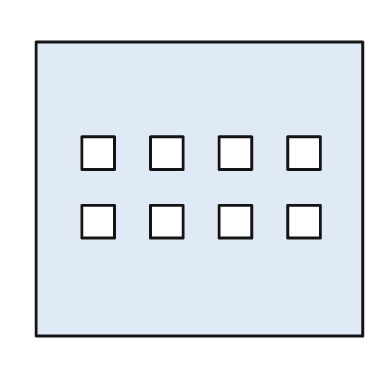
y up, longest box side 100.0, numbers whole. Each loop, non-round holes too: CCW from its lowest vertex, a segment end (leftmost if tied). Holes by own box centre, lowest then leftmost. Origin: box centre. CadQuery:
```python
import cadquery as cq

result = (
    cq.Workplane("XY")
    .moveTo(-50.0, -45.0)
    .lineTo(50.0, -45.0)
    .lineTo(50.0, 45.0)
    .lineTo(-50.0, 45.0)
    .close()
    .moveTo(-36.0, -15.0)
    .lineTo(-26.0, -15.0)
    .lineTo(-26.0, -5.0)
    .lineTo(-36.0, -5.0)
    .close()
    .moveTo(-15.0, -15.0)
    .lineTo(-5.0, -15.0)
    .lineTo(-5.0, -5.0)
    .lineTo(-15.0, -5.0)
    .close()
    .moveTo(6.0, -15.0)
    .lineTo(16.0, -15.0)
    .lineTo(16.0, -5.0)
    .lineTo(6.0, -5.0)
    .close()
    .moveTo(27.0, -15.0)
    .lineTo(37.0, -15.0)
    .lineTo(37.0, -5.0)
    .lineTo(27.0, -5.0)
    .close()
    .moveTo(-36.0, 6.0)
    .lineTo(-26.0, 6.0)
    .lineTo(-26.0, 16.0)
    .lineTo(-36.0, 16.0)
    .close()
    .moveTo(-15.0, 6.0)
    .lineTo(-5.0, 6.0)
    .lineTo(-5.0, 16.0)
    .lineTo(-15.0, 16.0)
    .close()
    .moveTo(6.0, 6.0)
    .lineTo(16.0, 6.0)
    .lineTo(16.0, 16.0)
    .lineTo(6.0, 16.0)
    .close()
    .moveTo(27.0, 6.0)
    .lineTo(37.0, 6.0)
    .lineTo(37.0, 16.0)
    .lineTo(27.0, 16.0)
    .close()
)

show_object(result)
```